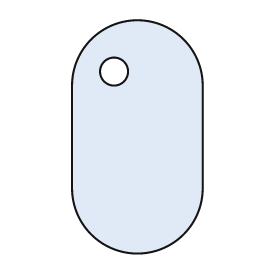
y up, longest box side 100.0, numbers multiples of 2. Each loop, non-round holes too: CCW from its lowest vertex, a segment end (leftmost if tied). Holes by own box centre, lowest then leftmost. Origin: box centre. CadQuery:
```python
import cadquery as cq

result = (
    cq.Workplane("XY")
    .moveTo(-28.0, -22.0)
    .threePointArc((0.0, -50.0), (28.0, -22.0))
    .lineTo(28.0, 22.0)
    .threePointArc((0.0, 50.0), (-28.0, 22.0))
    .close()
    .moveTo(-10.0, 28.0)
    .circle(6.0)
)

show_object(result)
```